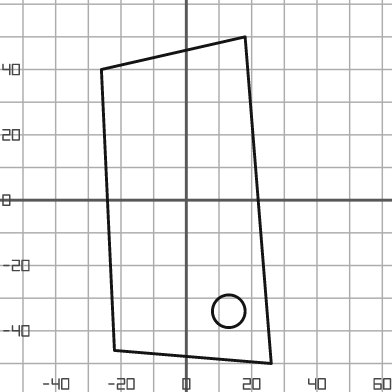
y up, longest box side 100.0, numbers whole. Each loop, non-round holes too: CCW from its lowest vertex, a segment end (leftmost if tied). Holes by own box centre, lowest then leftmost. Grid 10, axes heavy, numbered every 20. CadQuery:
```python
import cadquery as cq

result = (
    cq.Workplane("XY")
    .moveTo(26.0, -50.0)
    .lineTo(18.0, 50.0)
    .lineTo(-26.0, 40.0)
    .lineTo(-22.0, -46.0)
    .close()
    .moveTo(13.0, -34.0)
    .circle(5.0)
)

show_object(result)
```